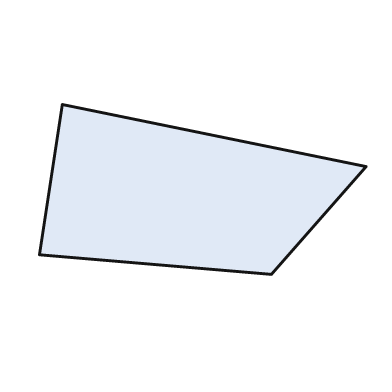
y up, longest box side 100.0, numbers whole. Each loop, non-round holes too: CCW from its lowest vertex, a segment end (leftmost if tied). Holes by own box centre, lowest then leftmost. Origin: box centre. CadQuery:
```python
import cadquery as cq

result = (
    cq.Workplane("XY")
    .moveTo(21.0, -26.0)
    .lineTo(50.0, 7.0)
    .lineTo(-43.0, 26.0)
    .lineTo(-50.0, -20.0)
    .close()
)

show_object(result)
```